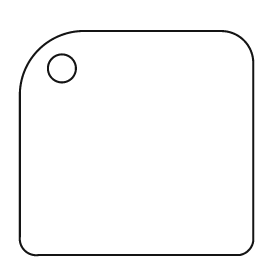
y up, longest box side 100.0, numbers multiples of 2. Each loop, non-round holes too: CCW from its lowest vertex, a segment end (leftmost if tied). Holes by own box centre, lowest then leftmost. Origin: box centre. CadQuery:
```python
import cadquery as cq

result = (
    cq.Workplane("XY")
    .moveTo(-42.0, -48.0)
    .lineTo(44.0, -48.0)
    .threePointArc((48.0, -46.0), (50.0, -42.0))
    .lineTo(50.0, 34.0)
    .threePointArc((46.0, 44.0), (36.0, 48.0))
    .lineTo(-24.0, 48.0)
    .threePointArc((-42.0, 40.0), (-50.0, 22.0))
    .lineTo(-50.0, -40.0)
    .threePointArc((-48.0, -46.0), (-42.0, -48.0))
    .close()
    .moveTo(-32.0, 32.0)
    .circle(6.0)
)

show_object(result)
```